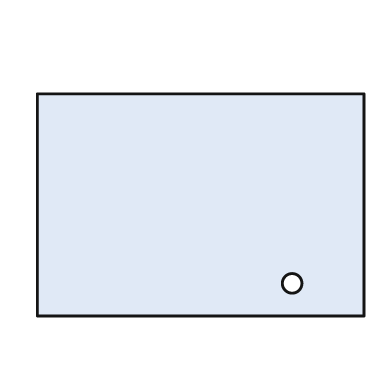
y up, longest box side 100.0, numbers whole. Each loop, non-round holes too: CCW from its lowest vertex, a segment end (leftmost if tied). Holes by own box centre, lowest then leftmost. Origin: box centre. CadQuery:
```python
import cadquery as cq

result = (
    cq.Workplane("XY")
    .moveTo(-50.0, -34.0)
    .lineTo(50.0, -34.0)
    .lineTo(50.0, 34.0)
    .lineTo(-50.0, 34.0)
    .close()
    .moveTo(28.0, -24.0)
    .circle(3.0)
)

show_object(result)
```